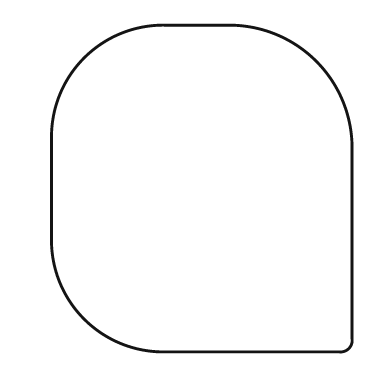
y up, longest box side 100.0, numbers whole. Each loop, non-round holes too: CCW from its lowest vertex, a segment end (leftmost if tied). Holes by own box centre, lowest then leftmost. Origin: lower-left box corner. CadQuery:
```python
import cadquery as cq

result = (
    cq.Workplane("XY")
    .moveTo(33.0, 0.0)
    .lineTo(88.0, 0.0)
    .threePointArc((91.0, 1.0), (92.0, 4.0))
    .lineTo(92.0, 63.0)
    .threePointArc((81.0, 89.0), (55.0, 100.0))
    .lineTo(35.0, 100.0)
    .threePointArc((10.0, 90.0), (0.0, 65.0))
    .lineTo(0.0, 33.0)
    .threePointArc((10.0, 10.0), (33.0, 0.0))
    .close()
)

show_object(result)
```